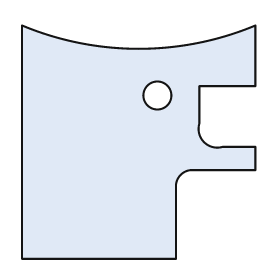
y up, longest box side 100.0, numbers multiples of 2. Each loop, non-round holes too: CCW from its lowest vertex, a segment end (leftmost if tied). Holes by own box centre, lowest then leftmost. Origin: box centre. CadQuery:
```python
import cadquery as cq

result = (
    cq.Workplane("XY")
    .moveTo(-50.0, -50.0)
    .lineTo(16.0, -50.0)
    .lineTo(16.0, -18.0)
    .threePointArc((18.0, -14.0), (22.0, -12.0))
    .lineTo(50.0, -12.0)
    .lineTo(50.0, -2.0)
    .lineTo(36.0, -2.0)
    .threePointArc((28.0, 0.0), (26.0, 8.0))
    .lineTo(26.0, 24.0)
    .lineTo(50.0, 24.0)
    .lineTo(50.0, 50.0)
    .threePointArc((0.0, 40.0), (-50.0, 50.0))
    .close()
    .moveTo(8.0, 20.0)
    .circle(6.0)
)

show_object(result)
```